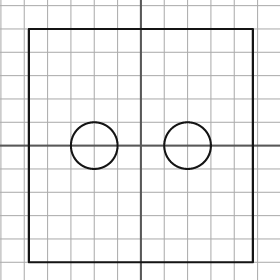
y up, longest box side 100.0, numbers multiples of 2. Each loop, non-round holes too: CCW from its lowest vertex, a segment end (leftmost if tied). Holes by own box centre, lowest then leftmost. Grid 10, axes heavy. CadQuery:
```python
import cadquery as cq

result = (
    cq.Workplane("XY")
    .moveTo(-48.0, -50.0)
    .lineTo(48.0, -50.0)
    .lineTo(48.0, 50.0)
    .lineTo(-48.0, 50.0)
    .close()
    .moveTo(-20.0, 0.0)
    .circle(10.0)
    .moveTo(20.0, 0.0)
    .circle(10.0)
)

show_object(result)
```